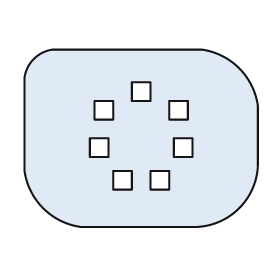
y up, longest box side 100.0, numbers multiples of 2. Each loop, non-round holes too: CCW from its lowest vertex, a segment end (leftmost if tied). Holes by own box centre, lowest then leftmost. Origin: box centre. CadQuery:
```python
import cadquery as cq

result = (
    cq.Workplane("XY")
    .moveTo(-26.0, -38.0)
    .lineTo(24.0, -38.0)
    .threePointArc((42.0, -30.0), (50.0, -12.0))
    .lineTo(50.0, 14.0)
    .threePointArc((42.0, 30.0), (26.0, 38.0))
    .lineTo(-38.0, 38.0)
    .threePointArc((-46.0, 34.0), (-50.0, 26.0))
    .lineTo(-50.0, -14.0)
    .threePointArc((-42.0, -30.0), (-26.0, -38.0))
    .close()
    .moveTo(-12.0, -22.0)
    .lineTo(-4.0, -22.0)
    .lineTo(-4.0, -14.0)
    .lineTo(-12.0, -14.0)
    .close()
    .moveTo(4.0, -22.0)
    .lineTo(12.0, -22.0)
    .lineTo(12.0, -14.0)
    .lineTo(4.0, -14.0)
    .close()
    .moveTo(-22.0, -8.0)
    .lineTo(-14.0, -8.0)
    .lineTo(-14.0, 0.0)
    .lineTo(-22.0, 0.0)
    .close()
    .moveTo(14.0, -8.0)
    .lineTo(22.0, -8.0)
    .lineTo(22.0, 0.0)
    .lineTo(14.0, 0.0)
    .close()
    .moveTo(-20.0, 8.0)
    .lineTo(-12.0, 8.0)
    .lineTo(-12.0, 16.0)
    .lineTo(-20.0, 16.0)
    .close()
    .moveTo(12.0, 8.0)
    .lineTo(20.0, 8.0)
    .lineTo(20.0, 16.0)
    .lineTo(12.0, 16.0)
    .close()
    .moveTo(-4.0, 16.0)
    .lineTo(4.0, 16.0)
    .lineTo(4.0, 24.0)
    .lineTo(-4.0, 24.0)
    .close()
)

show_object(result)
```